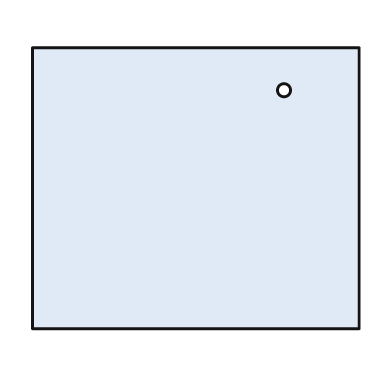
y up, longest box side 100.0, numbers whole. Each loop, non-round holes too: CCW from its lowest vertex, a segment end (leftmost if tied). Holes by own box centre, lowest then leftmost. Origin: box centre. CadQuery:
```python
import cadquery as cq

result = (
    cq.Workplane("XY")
    .moveTo(-50.0, -43.0)
    .lineTo(50.0, -43.0)
    .lineTo(50.0, 43.0)
    .lineTo(-50.0, 43.0)
    .close()
    .moveTo(27.0, 30.0)
    .circle(2.0)
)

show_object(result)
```